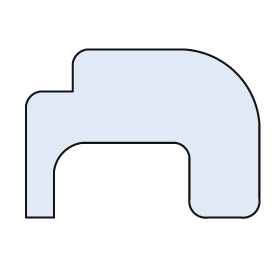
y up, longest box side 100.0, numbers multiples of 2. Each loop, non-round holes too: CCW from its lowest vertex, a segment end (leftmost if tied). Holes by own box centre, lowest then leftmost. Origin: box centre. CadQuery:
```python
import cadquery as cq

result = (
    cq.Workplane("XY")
    .moveTo(-50.0, -36.0)
    .lineTo(-38.0, -36.0)
    .lineTo(-38.0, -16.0)
    .threePointArc((-34.0, -8.0), (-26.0, -4.0))
    .lineTo(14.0, -4.0)
    .threePointArc((18.0, -6.0), (20.0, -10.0))
    .lineTo(20.0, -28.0)
    .threePointArc((22.0, -34.0), (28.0, -36.0))
    .lineTo(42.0, -36.0)
    .threePointArc((48.0, -34.0), (50.0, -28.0))
    .lineTo(50.0, 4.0)
    .threePointArc((40.0, 26.0), (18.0, 36.0))
    .lineTo(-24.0, 36.0)
    .threePointArc((-28.0, 34.0), (-30.0, 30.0))
    .lineTo(-30.0, 18.0)
    .lineTo(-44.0, 18.0)
    .threePointArc((-48.0, 16.0), (-50.0, 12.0))
    .close()
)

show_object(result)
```